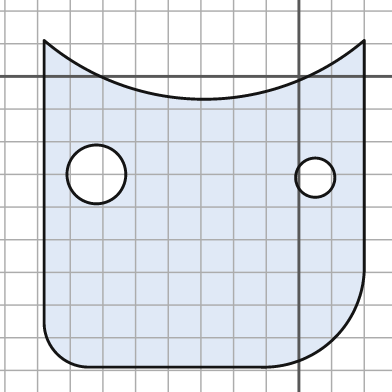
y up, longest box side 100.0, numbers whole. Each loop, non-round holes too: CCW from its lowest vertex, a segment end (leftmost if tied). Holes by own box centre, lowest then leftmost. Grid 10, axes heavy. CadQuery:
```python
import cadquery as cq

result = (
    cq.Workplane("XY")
    .moveTo(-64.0, -89.0)
    .lineTo(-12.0, -89.0)
    .threePointArc((11.0, -80.0), (20.0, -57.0))
    .lineTo(20.0, 11.0)
    .threePointArc((-29.0, -7.0), (-78.0, 11.0))
    .lineTo(-78.0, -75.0)
    .threePointArc((-74.0, -85.0), (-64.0, -89.0))
    .close()
    .moveTo(5.0, -31.0)
    .circle(6.0)
    .moveTo(-62.0, -30.0)
    .circle(9.0)
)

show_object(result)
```